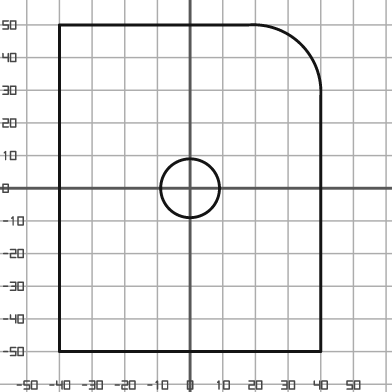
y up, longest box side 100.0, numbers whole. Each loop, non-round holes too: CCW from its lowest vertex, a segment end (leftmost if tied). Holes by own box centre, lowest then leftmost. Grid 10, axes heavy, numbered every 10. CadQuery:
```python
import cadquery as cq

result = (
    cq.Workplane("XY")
    .moveTo(-40.0, -50.0)
    .lineTo(40.0, -50.0)
    .lineTo(40.0, 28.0)
    .threePointArc((34.0, 44.0), (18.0, 50.0))
    .lineTo(-40.0, 50.0)
    .close()
    .moveTo(0.0, 0.0)
    .circle(9.0)
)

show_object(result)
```